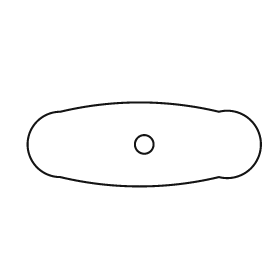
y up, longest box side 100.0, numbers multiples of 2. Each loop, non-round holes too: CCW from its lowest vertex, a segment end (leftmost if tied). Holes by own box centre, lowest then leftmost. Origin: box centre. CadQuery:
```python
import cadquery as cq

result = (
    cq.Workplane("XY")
    .moveTo(-36.0, -14.0)
    .threePointArc((-2.0, -18.0), (32.0, -14.0))
    .threePointArc((50.0, 0.0), (32.0, 14.0))
    .threePointArc((-2.0, 18.0), (-36.0, 14.0))
    .threePointArc((-50.0, 0.0), (-36.0, -14.0))
    .close()
    .moveTo(0.0, 0.0)
    .circle(4.0)
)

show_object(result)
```